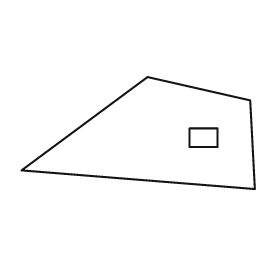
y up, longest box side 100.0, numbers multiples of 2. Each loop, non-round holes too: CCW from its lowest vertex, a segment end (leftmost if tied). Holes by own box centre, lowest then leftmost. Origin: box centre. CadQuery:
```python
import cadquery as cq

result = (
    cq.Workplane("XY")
    .moveTo(50.0, -24.0)
    .lineTo(48.0, 14.0)
    .lineTo(4.0, 24.0)
    .lineTo(-50.0, -16.0)
    .close()
    .moveTo(22.0, -6.0)
    .lineTo(34.0, -6.0)
    .lineTo(34.0, 2.0)
    .lineTo(22.0, 2.0)
    .close()
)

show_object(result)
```